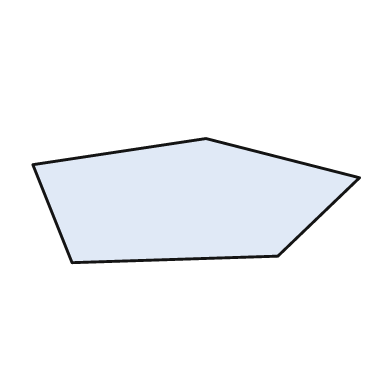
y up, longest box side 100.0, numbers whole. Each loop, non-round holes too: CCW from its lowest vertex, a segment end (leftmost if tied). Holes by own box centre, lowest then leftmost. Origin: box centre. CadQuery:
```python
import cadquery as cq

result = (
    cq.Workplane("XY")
    .moveTo(-38.0, -19.0)
    .lineTo(25.0, -17.0)
    .lineTo(50.0, 7.0)
    .lineTo(3.0, 19.0)
    .lineTo(-50.0, 11.0)
    .close()
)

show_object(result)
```